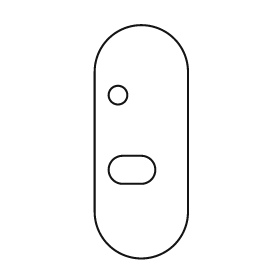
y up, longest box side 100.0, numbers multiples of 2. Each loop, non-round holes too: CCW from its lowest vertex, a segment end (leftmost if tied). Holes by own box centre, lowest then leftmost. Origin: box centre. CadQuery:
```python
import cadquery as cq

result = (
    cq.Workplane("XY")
    .moveTo(-20.0, -30.0)
    .threePointArc((0.0, -50.0), (20.0, -30.0))
    .lineTo(20.0, 30.0)
    .threePointArc((0.0, 50.0), (-20.0, 30.0))
    .close()
    .moveTo(-8.0, -18.0)
    .lineTo(0.0, -18.0)
    .threePointArc((6.0, -12.0), (0.0, -6.0))
    .lineTo(-8.0, -6.0)
    .threePointArc((-14.0, -12.0), (-8.0, -18.0))
    .close()
    .moveTo(-10.0, 20.0)
    .circle(4.0)
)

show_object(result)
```